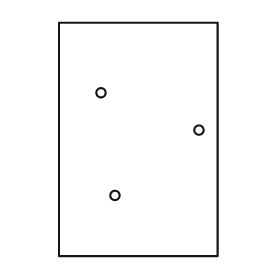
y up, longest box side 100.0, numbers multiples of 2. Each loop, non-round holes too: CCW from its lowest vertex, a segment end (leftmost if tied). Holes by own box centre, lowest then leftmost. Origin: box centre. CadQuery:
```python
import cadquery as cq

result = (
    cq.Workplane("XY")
    .moveTo(-34.0, -50.0)
    .lineTo(34.0, -50.0)
    .lineTo(34.0, 50.0)
    .lineTo(-34.0, 50.0)
    .close()
    .moveTo(-10.0, -24.0)
    .circle(2.0)
    .moveTo(26.0, 4.0)
    .circle(2.0)
    .moveTo(-16.0, 20.0)
    .circle(2.0)
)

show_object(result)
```